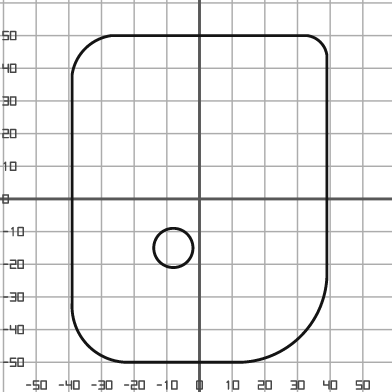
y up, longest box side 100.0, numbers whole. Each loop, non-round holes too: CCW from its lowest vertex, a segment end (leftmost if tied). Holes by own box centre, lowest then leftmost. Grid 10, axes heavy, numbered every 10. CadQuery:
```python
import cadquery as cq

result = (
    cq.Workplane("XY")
    .moveTo(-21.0, -50.0)
    .lineTo(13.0, -50.0)
    .threePointArc((31.0, -42.0), (39.0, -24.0))
    .lineTo(39.0, 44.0)
    .threePointArc((37.0, 48.0), (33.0, 50.0))
    .lineTo(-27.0, 50.0)
    .threePointArc((-35.0, 46.0), (-39.0, 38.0))
    .lineTo(-39.0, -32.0)
    .threePointArc((-34.0, -45.0), (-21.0, -50.0))
    .close()
    .moveTo(-8.0, -15.0)
    .circle(6.0)
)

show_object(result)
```